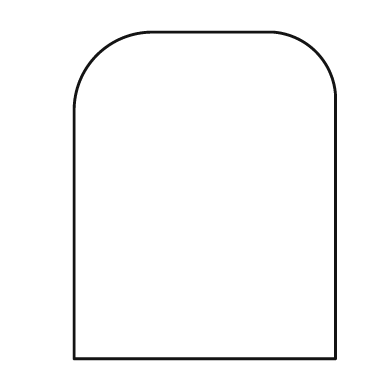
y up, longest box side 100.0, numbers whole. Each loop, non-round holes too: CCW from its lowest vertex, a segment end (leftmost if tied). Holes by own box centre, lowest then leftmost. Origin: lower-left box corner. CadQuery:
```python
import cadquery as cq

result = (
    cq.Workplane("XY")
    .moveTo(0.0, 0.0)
    .lineTo(80.0, 0.0)
    .lineTo(80.0, 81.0)
    .threePointArc((74.0, 94.0), (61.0, 100.0))
    .lineTo(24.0, 100.0)
    .threePointArc((7.0, 93.0), (0.0, 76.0))
    .close()
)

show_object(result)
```